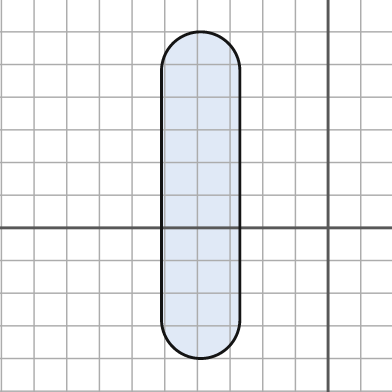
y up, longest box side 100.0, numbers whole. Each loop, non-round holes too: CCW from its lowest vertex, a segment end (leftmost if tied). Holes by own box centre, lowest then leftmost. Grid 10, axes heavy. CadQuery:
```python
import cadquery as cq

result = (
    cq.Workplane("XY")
    .moveTo(-51.0, -28.0)
    .threePointArc((-39.0, -40.0), (-27.0, -28.0))
    .lineTo(-27.0, 48.0)
    .threePointArc((-39.0, 60.0), (-51.0, 48.0))
    .close()
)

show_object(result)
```